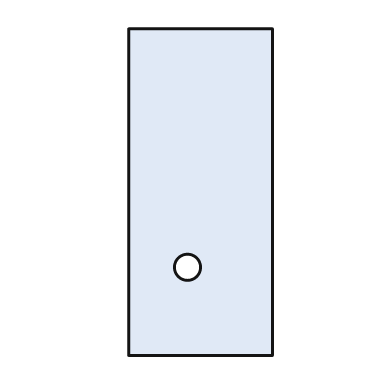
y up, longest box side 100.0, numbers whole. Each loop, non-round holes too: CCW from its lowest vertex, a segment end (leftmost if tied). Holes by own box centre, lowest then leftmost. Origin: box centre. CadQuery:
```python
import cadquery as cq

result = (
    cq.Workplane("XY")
    .moveTo(-22.0, -50.0)
    .lineTo(22.0, -50.0)
    .lineTo(22.0, 50.0)
    .lineTo(-22.0, 50.0)
    .close()
    .moveTo(-4.0, -23.0)
    .circle(4.0)
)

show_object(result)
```